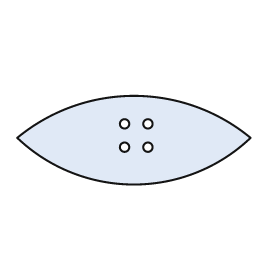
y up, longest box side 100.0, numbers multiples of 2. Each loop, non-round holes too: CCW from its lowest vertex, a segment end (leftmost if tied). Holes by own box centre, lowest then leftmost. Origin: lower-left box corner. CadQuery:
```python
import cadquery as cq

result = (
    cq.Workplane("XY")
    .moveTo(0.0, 20.0)
    .threePointArc((50.0, 0.0), (100.0, 20.0))
    .threePointArc((50.0, 38.0), (0.0, 20.0))
    .close()
    .moveTo(46.0, 16.0)
    .circle(2.0)
    .moveTo(56.0, 16.0)
    .circle(2.0)
    .moveTo(46.0, 26.0)
    .circle(2.0)
    .moveTo(56.0, 26.0)
    .circle(2.0)
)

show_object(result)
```